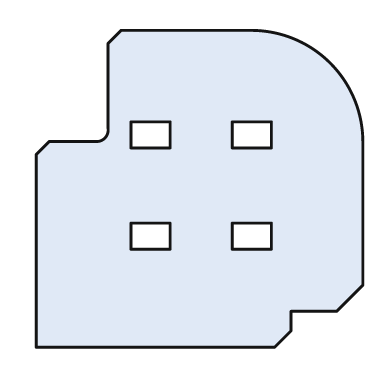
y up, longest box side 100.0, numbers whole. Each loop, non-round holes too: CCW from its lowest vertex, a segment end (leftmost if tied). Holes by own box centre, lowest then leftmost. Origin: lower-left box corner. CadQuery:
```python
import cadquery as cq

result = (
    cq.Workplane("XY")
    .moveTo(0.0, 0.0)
    .lineTo(73.0, 0.0)
    .lineTo(78.0, 5.0)
    .lineTo(78.0, 11.0)
    .lineTo(92.0, 11.0)
    .lineTo(100.0, 19.0)
    .lineTo(100.0, 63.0)
    .threePointArc((90.0, 87.0), (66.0, 97.0))
    .lineTo(26.0, 97.0)
    .lineTo(22.0, 93.0)
    .lineTo(22.0, 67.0)
    .threePointArc((21.0, 64.0), (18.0, 63.0))
    .lineTo(4.0, 63.0)
    .lineTo(0.0, 59.0)
    .close()
    .moveTo(29.0, 30.0)
    .lineTo(41.0, 30.0)
    .lineTo(41.0, 38.0)
    .lineTo(29.0, 38.0)
    .close()
    .moveTo(60.0, 30.0)
    .lineTo(72.0, 30.0)
    .lineTo(72.0, 38.0)
    .lineTo(60.0, 38.0)
    .close()
    .moveTo(29.0, 61.0)
    .lineTo(41.0, 61.0)
    .lineTo(41.0, 69.0)
    .lineTo(29.0, 69.0)
    .close()
    .moveTo(60.0, 61.0)
    .lineTo(72.0, 61.0)
    .lineTo(72.0, 69.0)
    .lineTo(60.0, 69.0)
    .close()
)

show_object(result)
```